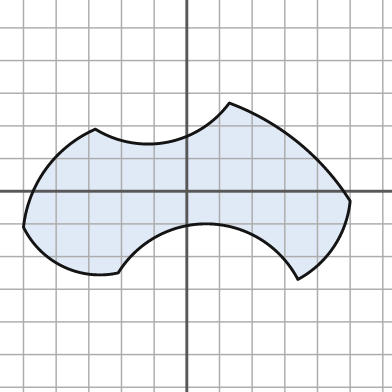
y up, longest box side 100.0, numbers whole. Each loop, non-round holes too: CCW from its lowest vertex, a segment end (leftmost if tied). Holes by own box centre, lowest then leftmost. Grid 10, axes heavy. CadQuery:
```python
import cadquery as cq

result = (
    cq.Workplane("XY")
    .moveTo(34.0, -27.0)
    .threePointArc((45.0, -17.0), (50.0, -3.0))
    .threePointArc((34.0, 15.0), (13.0, 27.0))
    .threePointArc((-6.0, 15.0), (-28.0, 19.0))
    .threePointArc((-43.0, 7.0), (-50.0, -11.0))
    .threePointArc((-38.0, -23.0), (-21.0, -25.0))
    .threePointArc((7.0, -10.0), (34.0, -27.0))
    .close()
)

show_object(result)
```